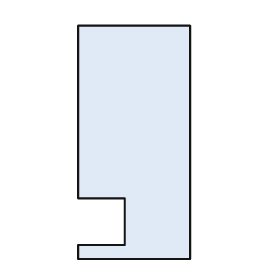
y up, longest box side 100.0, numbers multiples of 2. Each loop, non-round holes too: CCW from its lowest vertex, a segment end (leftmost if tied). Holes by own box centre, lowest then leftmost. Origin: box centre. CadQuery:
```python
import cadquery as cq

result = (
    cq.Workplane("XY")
    .moveTo(-24.0, -50.0)
    .lineTo(24.0, -50.0)
    .lineTo(24.0, 50.0)
    .lineTo(-24.0, 50.0)
    .lineTo(-24.0, -24.0)
    .lineTo(-4.0, -24.0)
    .lineTo(-4.0, -44.0)
    .lineTo(-24.0, -44.0)
    .close()
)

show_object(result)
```